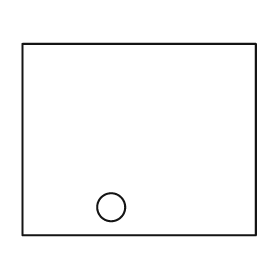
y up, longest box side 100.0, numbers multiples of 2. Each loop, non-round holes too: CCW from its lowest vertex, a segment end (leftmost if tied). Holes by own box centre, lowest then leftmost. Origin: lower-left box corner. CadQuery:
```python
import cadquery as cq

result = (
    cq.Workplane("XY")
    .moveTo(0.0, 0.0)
    .lineTo(100.0, 0.0)
    .lineTo(100.0, 82.0)
    .lineTo(0.0, 82.0)
    .close()
    .moveTo(38.0, 12.0)
    .circle(6.0)
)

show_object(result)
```